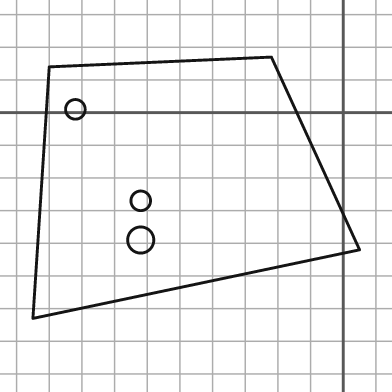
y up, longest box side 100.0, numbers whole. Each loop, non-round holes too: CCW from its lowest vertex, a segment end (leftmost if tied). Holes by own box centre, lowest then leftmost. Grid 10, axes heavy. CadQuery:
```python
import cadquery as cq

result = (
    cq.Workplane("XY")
    .moveTo(-95.0, -63.0)
    .lineTo(5.0, -42.0)
    .lineTo(-22.0, 17.0)
    .lineTo(-90.0, 14.0)
    .close()
    .moveTo(-62.0, -39.0)
    .circle(4.0)
    .moveTo(-62.0, -27.0)
    .circle(3.0)
    .moveTo(-82.0, 1.0)
    .circle(3.0)
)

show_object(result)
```